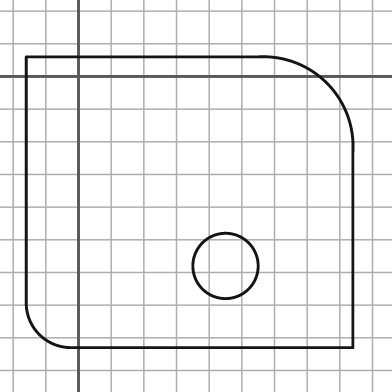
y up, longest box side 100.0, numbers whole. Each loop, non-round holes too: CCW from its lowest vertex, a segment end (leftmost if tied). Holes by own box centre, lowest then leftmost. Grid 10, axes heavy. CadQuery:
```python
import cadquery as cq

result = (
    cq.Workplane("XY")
    .moveTo(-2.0, -83.0)
    .lineTo(84.0, -83.0)
    .lineTo(84.0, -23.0)
    .threePointArc((76.0, -2.0), (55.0, 6.0))
    .lineTo(-16.0, 6.0)
    .lineTo(-16.0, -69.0)
    .threePointArc((-12.0, -79.0), (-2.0, -83.0))
    .close()
    .moveTo(45.0, -58.0)
    .circle(10.0)
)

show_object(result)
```